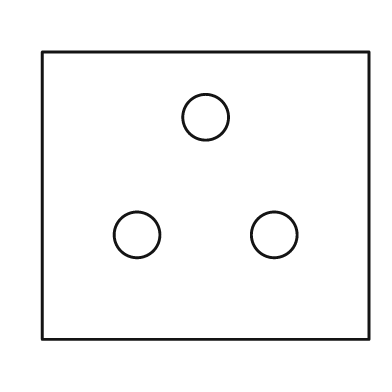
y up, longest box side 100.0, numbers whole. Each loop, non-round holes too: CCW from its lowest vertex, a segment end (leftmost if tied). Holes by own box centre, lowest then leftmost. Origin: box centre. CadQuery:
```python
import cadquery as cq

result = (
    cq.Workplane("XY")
    .moveTo(-50.0, -44.0)
    .lineTo(50.0, -44.0)
    .lineTo(50.0, 44.0)
    .lineTo(-50.0, 44.0)
    .close()
    .moveTo(-21.0, -12.0)
    .circle(7.0)
    .moveTo(21.0, -12.0)
    .circle(7.0)
    .moveTo(0.0, 24.0)
    .circle(7.0)
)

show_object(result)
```